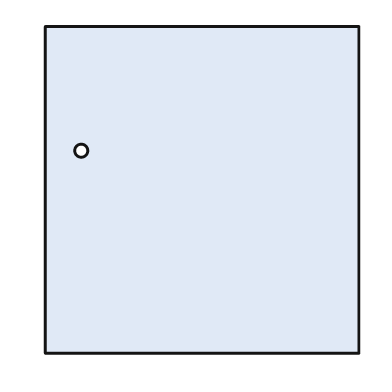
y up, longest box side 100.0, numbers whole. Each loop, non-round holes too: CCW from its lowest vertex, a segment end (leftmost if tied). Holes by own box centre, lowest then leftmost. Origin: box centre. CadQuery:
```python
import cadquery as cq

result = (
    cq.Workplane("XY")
    .moveTo(-48.0, -50.0)
    .lineTo(48.0, -50.0)
    .lineTo(48.0, 50.0)
    .lineTo(-48.0, 50.0)
    .close()
    .moveTo(-37.0, 12.0)
    .circle(2.0)
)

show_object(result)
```